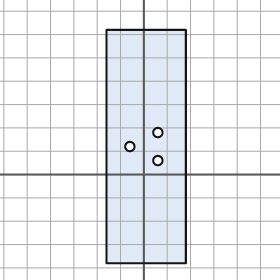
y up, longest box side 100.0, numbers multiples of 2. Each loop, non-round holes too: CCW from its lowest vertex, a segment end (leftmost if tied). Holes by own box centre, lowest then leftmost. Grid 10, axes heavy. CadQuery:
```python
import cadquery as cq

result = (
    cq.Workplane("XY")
    .moveTo(-16.0, -38.0)
    .lineTo(18.0, -38.0)
    .lineTo(18.0, 62.0)
    .lineTo(-16.0, 62.0)
    .close()
    .moveTo(6.0, 6.0)
    .circle(2.0)
    .moveTo(-6.0, 12.0)
    .circle(2.0)
    .moveTo(6.0, 18.0)
    .circle(2.0)
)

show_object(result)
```